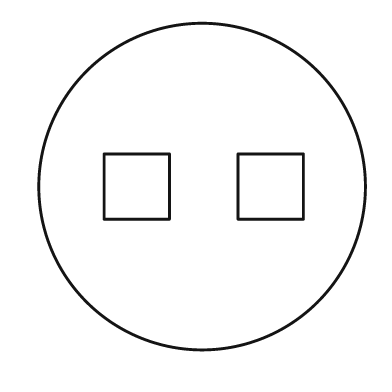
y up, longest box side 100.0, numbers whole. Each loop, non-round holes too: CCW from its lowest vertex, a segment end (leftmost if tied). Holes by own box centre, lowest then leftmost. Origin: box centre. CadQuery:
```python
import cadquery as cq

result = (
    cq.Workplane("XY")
    .moveTo(0.0, 0.0)
    .circle(50.0)
    .moveTo(-30.0, -10.0)
    .lineTo(-10.0, -10.0)
    .lineTo(-10.0, 10.0)
    .lineTo(-30.0, 10.0)
    .close()
    .moveTo(11.0, -10.0)
    .lineTo(31.0, -10.0)
    .lineTo(31.0, 10.0)
    .lineTo(11.0, 10.0)
    .close()
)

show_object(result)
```